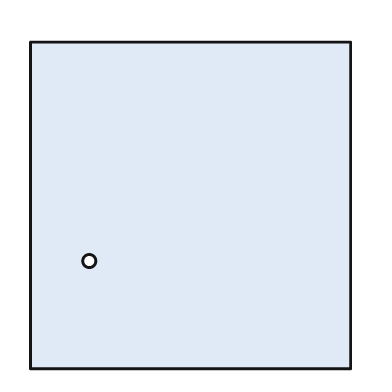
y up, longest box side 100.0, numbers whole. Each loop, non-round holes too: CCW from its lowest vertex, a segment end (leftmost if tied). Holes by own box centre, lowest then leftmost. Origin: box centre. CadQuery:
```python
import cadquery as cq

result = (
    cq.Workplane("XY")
    .moveTo(-49.0, -50.0)
    .lineTo(49.0, -50.0)
    .lineTo(49.0, 50.0)
    .lineTo(-49.0, 50.0)
    .close()
    .moveTo(-31.0, -17.0)
    .circle(2.0)
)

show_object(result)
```